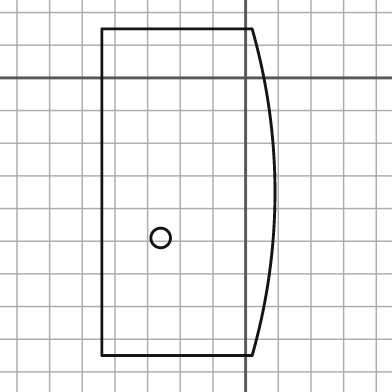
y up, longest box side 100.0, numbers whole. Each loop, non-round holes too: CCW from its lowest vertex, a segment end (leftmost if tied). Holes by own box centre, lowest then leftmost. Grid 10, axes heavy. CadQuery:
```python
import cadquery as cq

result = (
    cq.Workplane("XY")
    .moveTo(-44.0, -85.0)
    .lineTo(2.0, -85.0)
    .threePointArc((9.0, -35.0), (2.0, 15.0))
    .lineTo(-44.0, 15.0)
    .close()
    .moveTo(-26.0, -49.0)
    .circle(3.0)
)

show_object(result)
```